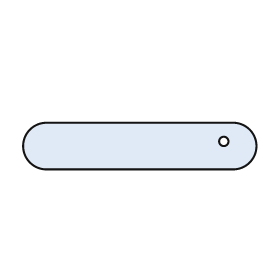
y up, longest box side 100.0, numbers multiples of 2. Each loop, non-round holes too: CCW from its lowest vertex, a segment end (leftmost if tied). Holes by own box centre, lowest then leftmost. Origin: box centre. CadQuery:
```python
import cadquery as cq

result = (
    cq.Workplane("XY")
    .moveTo(-40.0, -10.0)
    .lineTo(40.0, -10.0)
    .threePointArc((50.0, 0.0), (40.0, 10.0))
    .lineTo(-40.0, 10.0)
    .threePointArc((-50.0, 0.0), (-40.0, -10.0))
    .close()
    .moveTo(36.0, 2.0)
    .circle(2.0)
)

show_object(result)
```